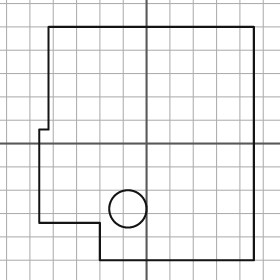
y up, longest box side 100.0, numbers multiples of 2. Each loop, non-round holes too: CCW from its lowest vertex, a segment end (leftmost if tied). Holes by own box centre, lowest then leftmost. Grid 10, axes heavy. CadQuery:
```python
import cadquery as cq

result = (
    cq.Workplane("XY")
    .moveTo(-20.0, -50.0)
    .lineTo(46.0, -50.0)
    .lineTo(46.0, 50.0)
    .lineTo(-42.0, 50.0)
    .lineTo(-42.0, 6.0)
    .lineTo(-46.0, 6.0)
    .lineTo(-46.0, -34.0)
    .lineTo(-20.0, -34.0)
    .close()
    .moveTo(-8.0, -28.0)
    .circle(8.0)
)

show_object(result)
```